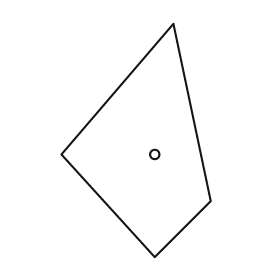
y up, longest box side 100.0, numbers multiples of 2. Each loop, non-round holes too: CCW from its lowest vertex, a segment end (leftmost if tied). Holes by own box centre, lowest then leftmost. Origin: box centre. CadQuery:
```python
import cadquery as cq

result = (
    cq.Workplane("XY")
    .moveTo(8.0, -50.0)
    .lineTo(32.0, -26.0)
    .lineTo(16.0, 50.0)
    .lineTo(-32.0, -6.0)
    .close()
    .moveTo(8.0, -6.0)
    .circle(2.0)
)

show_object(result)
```